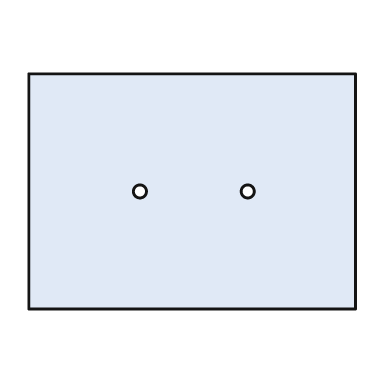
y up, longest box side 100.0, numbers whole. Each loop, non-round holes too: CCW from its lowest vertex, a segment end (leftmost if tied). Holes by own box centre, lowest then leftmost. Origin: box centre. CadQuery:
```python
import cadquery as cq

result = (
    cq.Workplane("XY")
    .moveTo(-50.0, -36.0)
    .lineTo(50.0, -36.0)
    .lineTo(50.0, 36.0)
    .lineTo(-50.0, 36.0)
    .close()
    .moveTo(-16.0, 0.0)
    .circle(2.0)
    .moveTo(17.0, 0.0)
    .circle(2.0)
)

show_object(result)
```